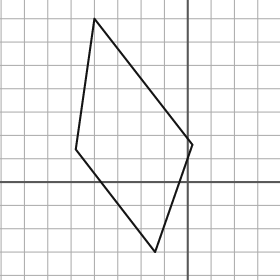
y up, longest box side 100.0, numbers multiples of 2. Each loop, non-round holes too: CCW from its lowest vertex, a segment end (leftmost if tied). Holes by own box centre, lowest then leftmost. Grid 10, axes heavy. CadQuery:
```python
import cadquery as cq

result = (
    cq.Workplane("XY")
    .moveTo(-14.0, -30.0)
    .lineTo(2.0, 16.0)
    .lineTo(-40.0, 70.0)
    .lineTo(-48.0, 14.0)
    .close()
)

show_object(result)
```